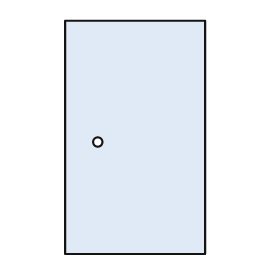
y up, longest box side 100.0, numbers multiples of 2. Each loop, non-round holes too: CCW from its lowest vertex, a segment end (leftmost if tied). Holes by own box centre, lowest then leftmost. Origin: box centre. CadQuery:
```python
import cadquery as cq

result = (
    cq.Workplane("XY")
    .moveTo(-30.0, -50.0)
    .lineTo(30.0, -50.0)
    .lineTo(30.0, 50.0)
    .lineTo(-30.0, 50.0)
    .close()
    .moveTo(-16.0, -2.0)
    .circle(2.0)
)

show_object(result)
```